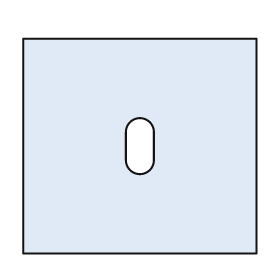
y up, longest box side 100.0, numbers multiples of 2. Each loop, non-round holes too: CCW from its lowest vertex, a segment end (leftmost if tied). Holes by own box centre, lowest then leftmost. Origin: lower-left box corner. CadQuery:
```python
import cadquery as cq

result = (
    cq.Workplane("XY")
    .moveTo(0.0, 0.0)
    .lineTo(100.0, 0.0)
    .lineTo(100.0, 92.0)
    .lineTo(0.0, 92.0)
    .close()
    .moveTo(44.0, 40.0)
    .threePointArc((50.0, 34.0), (56.0, 40.0))
    .lineTo(56.0, 52.0)
    .threePointArc((50.0, 58.0), (44.0, 52.0))
    .close()
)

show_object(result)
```